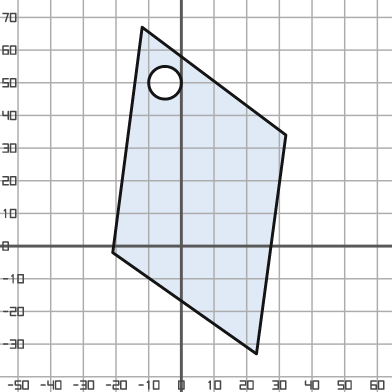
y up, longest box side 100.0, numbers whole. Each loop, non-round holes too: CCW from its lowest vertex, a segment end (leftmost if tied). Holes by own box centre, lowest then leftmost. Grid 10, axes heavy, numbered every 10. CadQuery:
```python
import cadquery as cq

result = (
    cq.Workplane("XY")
    .moveTo(23.0, -33.0)
    .lineTo(32.0, 34.0)
    .lineTo(-12.0, 67.0)
    .lineTo(-21.0, -2.0)
    .close()
    .moveTo(-5.0, 50.0)
    .circle(5.0)
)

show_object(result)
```